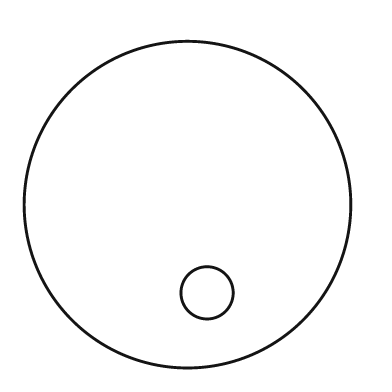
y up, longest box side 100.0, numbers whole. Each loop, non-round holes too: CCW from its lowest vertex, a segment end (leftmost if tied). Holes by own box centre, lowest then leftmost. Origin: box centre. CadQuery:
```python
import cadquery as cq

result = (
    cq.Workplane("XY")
    .moveTo(0.0, 0.0)
    .circle(50.0)
    .moveTo(6.0, -27.0)
    .circle(8.0)
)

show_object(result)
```